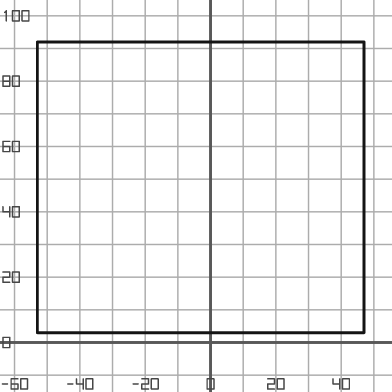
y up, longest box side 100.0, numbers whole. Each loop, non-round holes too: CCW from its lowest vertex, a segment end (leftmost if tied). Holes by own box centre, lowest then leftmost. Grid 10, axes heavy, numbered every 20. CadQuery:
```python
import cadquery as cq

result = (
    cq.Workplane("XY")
    .moveTo(-53.0, 3.0)
    .lineTo(47.0, 3.0)
    .lineTo(47.0, 92.0)
    .lineTo(-53.0, 92.0)
    .close()
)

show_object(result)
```